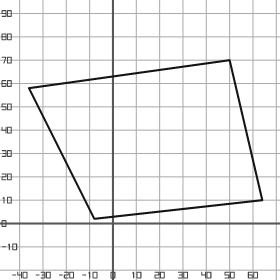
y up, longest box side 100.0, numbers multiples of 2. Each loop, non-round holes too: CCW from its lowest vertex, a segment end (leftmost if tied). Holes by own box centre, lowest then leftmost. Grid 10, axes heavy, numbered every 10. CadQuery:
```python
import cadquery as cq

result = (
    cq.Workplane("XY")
    .moveTo(-8.0, 2.0)
    .lineTo(64.0, 10.0)
    .lineTo(50.0, 70.0)
    .lineTo(-36.0, 58.0)
    .close()
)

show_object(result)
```